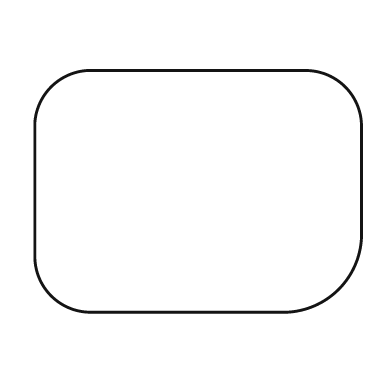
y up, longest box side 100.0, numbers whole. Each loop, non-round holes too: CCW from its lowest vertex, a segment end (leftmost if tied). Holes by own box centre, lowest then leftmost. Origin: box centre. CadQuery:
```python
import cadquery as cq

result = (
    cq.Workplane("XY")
    .moveTo(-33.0, -37.0)
    .lineTo(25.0, -37.0)
    .threePointArc((43.0, -30.0), (50.0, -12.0))
    .lineTo(50.0, 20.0)
    .threePointArc((45.0, 32.0), (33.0, 37.0))
    .lineTo(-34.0, 37.0)
    .threePointArc((-45.0, 32.0), (-50.0, 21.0))
    .lineTo(-50.0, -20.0)
    .threePointArc((-45.0, -32.0), (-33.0, -37.0))
    .close()
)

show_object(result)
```